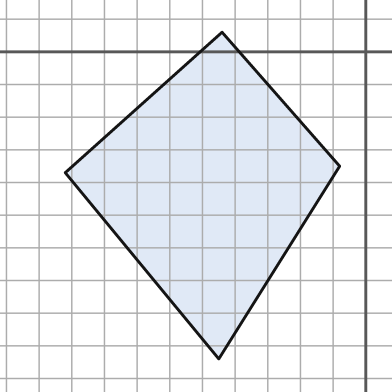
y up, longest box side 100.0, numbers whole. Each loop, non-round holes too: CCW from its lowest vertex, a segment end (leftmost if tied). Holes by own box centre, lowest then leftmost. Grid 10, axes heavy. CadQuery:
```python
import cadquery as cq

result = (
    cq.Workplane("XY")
    .moveTo(-45.0, -94.0)
    .lineTo(-8.0, -35.0)
    .lineTo(-44.0, 6.0)
    .lineTo(-92.0, -37.0)
    .close()
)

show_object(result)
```